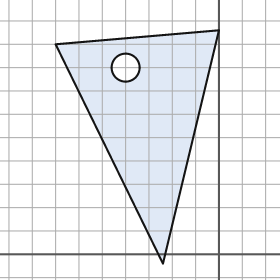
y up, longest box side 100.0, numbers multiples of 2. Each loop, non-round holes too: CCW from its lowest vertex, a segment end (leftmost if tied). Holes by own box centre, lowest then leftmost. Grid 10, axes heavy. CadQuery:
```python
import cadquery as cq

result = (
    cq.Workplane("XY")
    .moveTo(-24.0, -4.0)
    .lineTo(0.0, 96.0)
    .lineTo(-70.0, 90.0)
    .close()
    .moveTo(-40.0, 80.0)
    .circle(6.0)
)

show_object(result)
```